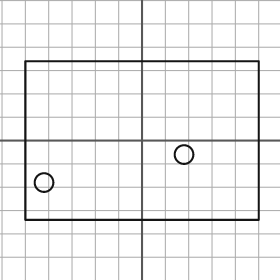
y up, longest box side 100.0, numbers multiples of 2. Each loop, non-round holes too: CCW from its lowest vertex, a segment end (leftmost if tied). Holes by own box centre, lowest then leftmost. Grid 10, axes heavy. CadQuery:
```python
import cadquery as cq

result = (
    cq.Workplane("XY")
    .moveTo(-50.0, -34.0)
    .lineTo(50.0, -34.0)
    .lineTo(50.0, 34.0)
    .lineTo(-50.0, 34.0)
    .close()
    .moveTo(-42.0, -18.0)
    .circle(4.0)
    .moveTo(18.0, -6.0)
    .circle(4.0)
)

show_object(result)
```